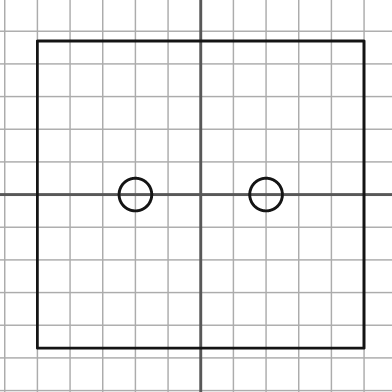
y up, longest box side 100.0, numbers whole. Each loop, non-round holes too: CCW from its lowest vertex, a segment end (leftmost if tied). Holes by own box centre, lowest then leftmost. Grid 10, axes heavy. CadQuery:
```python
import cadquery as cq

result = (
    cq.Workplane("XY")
    .moveTo(-50.0, -47.0)
    .lineTo(50.0, -47.0)
    .lineTo(50.0, 47.0)
    .lineTo(-50.0, 47.0)
    .close()
    .moveTo(-20.0, 0.0)
    .circle(5.0)
    .moveTo(20.0, 0.0)
    .circle(5.0)
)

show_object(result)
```